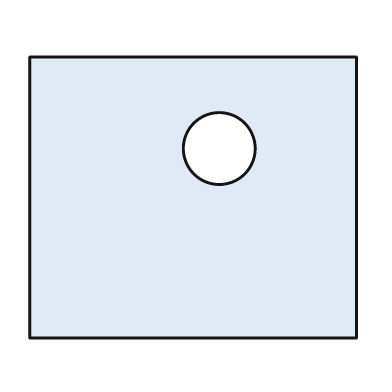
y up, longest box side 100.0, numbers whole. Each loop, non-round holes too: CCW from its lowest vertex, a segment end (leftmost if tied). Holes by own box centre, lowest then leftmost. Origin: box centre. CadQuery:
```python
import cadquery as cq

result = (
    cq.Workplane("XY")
    .moveTo(-50.0, -43.0)
    .lineTo(50.0, -43.0)
    .lineTo(50.0, 43.0)
    .lineTo(-50.0, 43.0)
    .close()
    .moveTo(8.0, 15.0)
    .circle(11.0)
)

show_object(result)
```